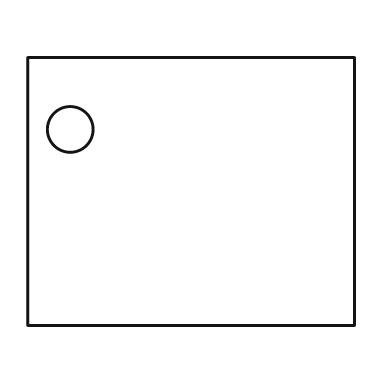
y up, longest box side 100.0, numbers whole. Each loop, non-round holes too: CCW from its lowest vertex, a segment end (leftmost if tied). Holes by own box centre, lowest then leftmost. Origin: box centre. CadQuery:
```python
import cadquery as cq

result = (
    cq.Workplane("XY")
    .moveTo(-50.0, -41.0)
    .lineTo(50.0, -41.0)
    .lineTo(50.0, 41.0)
    .lineTo(-50.0, 41.0)
    .close()
    .moveTo(-37.0, 19.0)
    .circle(7.0)
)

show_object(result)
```